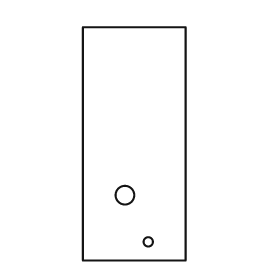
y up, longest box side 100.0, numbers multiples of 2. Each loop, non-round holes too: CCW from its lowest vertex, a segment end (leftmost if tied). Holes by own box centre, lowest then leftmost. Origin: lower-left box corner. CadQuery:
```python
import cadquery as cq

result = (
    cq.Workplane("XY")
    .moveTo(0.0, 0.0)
    .lineTo(44.0, 0.0)
    .lineTo(44.0, 100.0)
    .lineTo(0.0, 100.0)
    .close()
    .moveTo(28.0, 8.0)
    .circle(2.0)
    .moveTo(18.0, 28.0)
    .circle(4.0)
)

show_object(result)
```